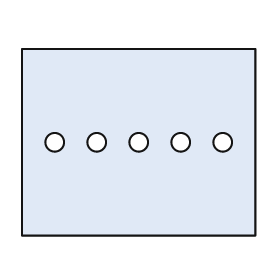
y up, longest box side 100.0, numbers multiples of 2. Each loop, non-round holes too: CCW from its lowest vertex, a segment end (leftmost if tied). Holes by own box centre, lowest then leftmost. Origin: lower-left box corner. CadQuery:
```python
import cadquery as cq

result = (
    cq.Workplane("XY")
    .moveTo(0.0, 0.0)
    .lineTo(100.0, 0.0)
    .lineTo(100.0, 80.0)
    .lineTo(0.0, 80.0)
    .close()
    .moveTo(14.0, 40.0)
    .circle(4.0)
    .moveTo(32.0, 40.0)
    .circle(4.0)
    .moveTo(50.0, 40.0)
    .circle(4.0)
    .moveTo(68.0, 40.0)
    .circle(4.0)
    .moveTo(86.0, 40.0)
    .circle(4.0)
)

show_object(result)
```